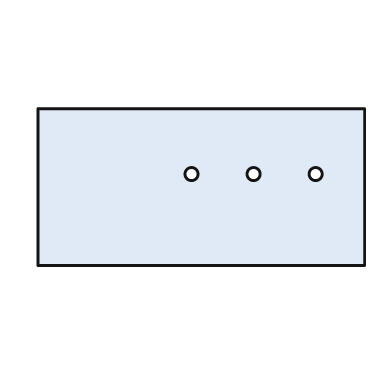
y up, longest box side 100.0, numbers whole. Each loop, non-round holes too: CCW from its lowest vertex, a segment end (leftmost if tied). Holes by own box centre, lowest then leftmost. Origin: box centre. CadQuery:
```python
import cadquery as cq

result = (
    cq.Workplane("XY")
    .moveTo(-50.0, -24.0)
    .lineTo(50.0, -24.0)
    .lineTo(50.0, 24.0)
    .lineTo(-50.0, 24.0)
    .close()
    .moveTo(-3.0, 4.0)
    .circle(2.0)
    .moveTo(16.0, 4.0)
    .circle(2.0)
    .moveTo(35.0, 4.0)
    .circle(2.0)
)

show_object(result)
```